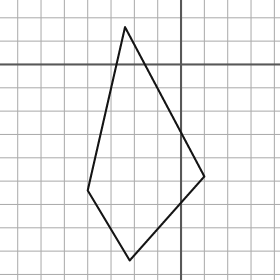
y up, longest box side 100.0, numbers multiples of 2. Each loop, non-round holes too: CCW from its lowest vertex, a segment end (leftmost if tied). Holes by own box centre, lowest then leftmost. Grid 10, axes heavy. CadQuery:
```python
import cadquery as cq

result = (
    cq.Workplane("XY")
    .moveTo(-22.0, -84.0)
    .lineTo(10.0, -48.0)
    .lineTo(-24.0, 16.0)
    .lineTo(-40.0, -54.0)
    .close()
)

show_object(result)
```